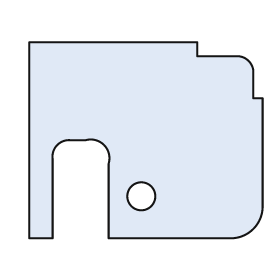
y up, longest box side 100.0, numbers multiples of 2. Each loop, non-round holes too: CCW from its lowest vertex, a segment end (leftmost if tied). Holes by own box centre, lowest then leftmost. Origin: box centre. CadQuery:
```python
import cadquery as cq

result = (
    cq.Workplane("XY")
    .moveTo(-50.0, -42.0)
    .lineTo(-40.0, -42.0)
    .lineTo(-40.0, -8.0)
    .threePointArc((-38.0, -2.0), (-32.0, 0.0))
    .lineTo(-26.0, 0.0)
    .threePointArc((-18.0, -2.0), (-16.0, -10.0))
    .lineTo(-16.0, -42.0)
    .lineTo(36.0, -42.0)
    .threePointArc((46.0, -38.0), (50.0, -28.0))
    .lineTo(50.0, 18.0)
    .lineTo(46.0, 18.0)
    .lineTo(46.0, 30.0)
    .threePointArc((44.0, 34.0), (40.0, 36.0))
    .lineTo(22.0, 36.0)
    .lineTo(22.0, 42.0)
    .lineTo(-50.0, 42.0)
    .close()
    .moveTo(-2.0, -24.0)
    .circle(6.0)
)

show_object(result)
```